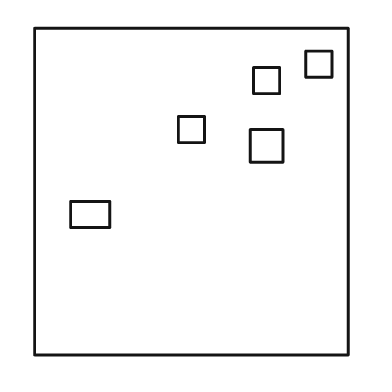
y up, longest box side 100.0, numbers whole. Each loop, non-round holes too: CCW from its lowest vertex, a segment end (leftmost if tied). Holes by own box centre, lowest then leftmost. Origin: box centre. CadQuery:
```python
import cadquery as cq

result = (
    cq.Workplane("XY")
    .moveTo(-48.0, -50.0)
    .lineTo(48.0, -50.0)
    .lineTo(48.0, 50.0)
    .lineTo(-48.0, 50.0)
    .close()
    .moveTo(-37.0, -11.0)
    .lineTo(-25.0, -11.0)
    .lineTo(-25.0, -3.0)
    .lineTo(-37.0, -3.0)
    .close()
    .moveTo(18.0, 9.0)
    .lineTo(28.0, 9.0)
    .lineTo(28.0, 19.0)
    .lineTo(18.0, 19.0)
    .close()
    .moveTo(-4.0, 15.0)
    .lineTo(4.0, 15.0)
    .lineTo(4.0, 23.0)
    .lineTo(-4.0, 23.0)
    .close()
    .moveTo(19.0, 30.0)
    .lineTo(27.0, 30.0)
    .lineTo(27.0, 38.0)
    .lineTo(19.0, 38.0)
    .close()
    .moveTo(35.0, 35.0)
    .lineTo(43.0, 35.0)
    .lineTo(43.0, 43.0)
    .lineTo(35.0, 43.0)
    .close()
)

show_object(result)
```